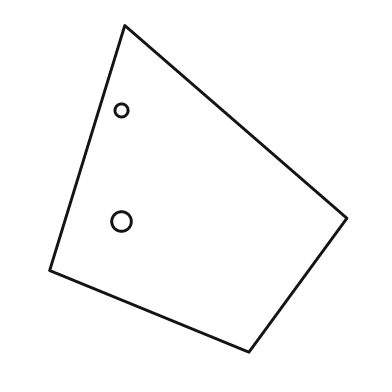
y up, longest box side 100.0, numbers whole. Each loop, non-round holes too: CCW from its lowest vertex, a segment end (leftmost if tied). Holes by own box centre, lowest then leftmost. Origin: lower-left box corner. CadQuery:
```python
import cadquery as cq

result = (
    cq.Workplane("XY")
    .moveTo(61.0, 0.0)
    .lineTo(91.0, 41.0)
    .lineTo(23.0, 100.0)
    .lineTo(0.0, 25.0)
    .close()
    .moveTo(22.0, 40.0)
    .circle(3.0)
    .moveTo(22.0, 74.0)
    .circle(2.0)
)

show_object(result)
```